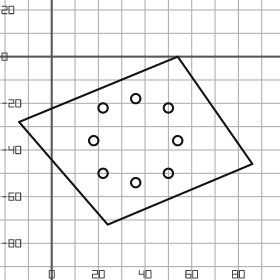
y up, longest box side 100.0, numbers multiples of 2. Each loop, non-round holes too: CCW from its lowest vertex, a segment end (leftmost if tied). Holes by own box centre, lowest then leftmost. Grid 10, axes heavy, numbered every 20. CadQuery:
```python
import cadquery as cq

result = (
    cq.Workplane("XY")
    .moveTo(24.0, -72.0)
    .lineTo(86.0, -46.0)
    .lineTo(54.0, 0.0)
    .lineTo(-14.0, -28.0)
    .close()
    .moveTo(36.0, -54.0)
    .circle(2.0)
    .moveTo(22.0, -50.0)
    .circle(2.0)
    .moveTo(50.0, -50.0)
    .circle(2.0)
    .moveTo(18.0, -36.0)
    .circle(2.0)
    .moveTo(54.0, -36.0)
    .circle(2.0)
    .moveTo(22.0, -22.0)
    .circle(2.0)
    .moveTo(50.0, -22.0)
    .circle(2.0)
    .moveTo(36.0, -18.0)
    .circle(2.0)
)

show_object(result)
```